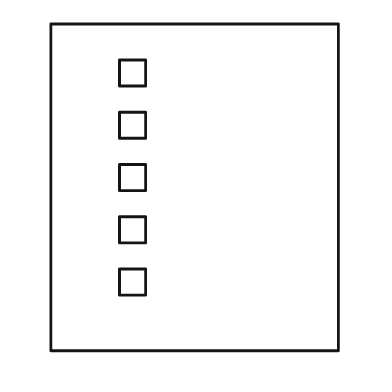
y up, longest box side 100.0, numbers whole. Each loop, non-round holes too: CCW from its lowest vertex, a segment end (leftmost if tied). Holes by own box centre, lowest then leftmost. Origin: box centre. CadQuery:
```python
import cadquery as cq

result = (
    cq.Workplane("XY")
    .moveTo(-44.0, -50.0)
    .lineTo(44.0, -50.0)
    .lineTo(44.0, 50.0)
    .lineTo(-44.0, 50.0)
    .close()
    .moveTo(-23.0, -33.0)
    .lineTo(-15.0, -33.0)
    .lineTo(-15.0, -25.0)
    .lineTo(-23.0, -25.0)
    .close()
    .moveTo(-23.0, -17.0)
    .lineTo(-15.0, -17.0)
    .lineTo(-15.0, -9.0)
    .lineTo(-23.0, -9.0)
    .close()
    .moveTo(-23.0, -1.0)
    .lineTo(-15.0, -1.0)
    .lineTo(-15.0, 7.0)
    .lineTo(-23.0, 7.0)
    .close()
    .moveTo(-23.0, 15.0)
    .lineTo(-15.0, 15.0)
    .lineTo(-15.0, 23.0)
    .lineTo(-23.0, 23.0)
    .close()
    .moveTo(-23.0, 31.0)
    .lineTo(-15.0, 31.0)
    .lineTo(-15.0, 39.0)
    .lineTo(-23.0, 39.0)
    .close()
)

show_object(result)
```